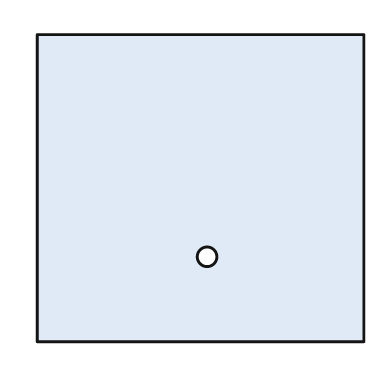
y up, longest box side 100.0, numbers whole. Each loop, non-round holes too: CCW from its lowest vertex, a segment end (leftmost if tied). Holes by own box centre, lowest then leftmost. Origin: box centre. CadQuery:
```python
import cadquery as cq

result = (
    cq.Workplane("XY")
    .moveTo(-50.0, -47.0)
    .lineTo(50.0, -47.0)
    .lineTo(50.0, 47.0)
    .lineTo(-50.0, 47.0)
    .close()
    .moveTo(2.0, -21.0)
    .circle(3.0)
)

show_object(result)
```